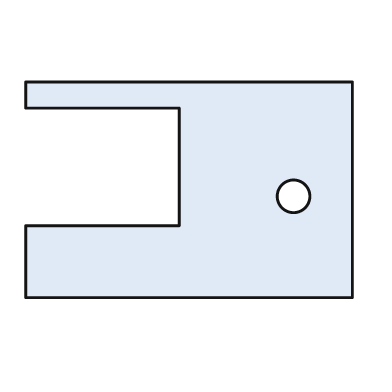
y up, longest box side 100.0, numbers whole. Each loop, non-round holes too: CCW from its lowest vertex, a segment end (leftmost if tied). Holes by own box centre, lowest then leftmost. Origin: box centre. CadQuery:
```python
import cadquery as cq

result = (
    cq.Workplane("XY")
    .moveTo(-50.0, -33.0)
    .lineTo(50.0, -33.0)
    .lineTo(50.0, 33.0)
    .lineTo(-50.0, 33.0)
    .lineTo(-50.0, 25.0)
    .lineTo(-3.0, 25.0)
    .lineTo(-3.0, -11.0)
    .lineTo(-50.0, -11.0)
    .close()
    .moveTo(32.0, -2.0)
    .circle(5.0)
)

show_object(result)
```